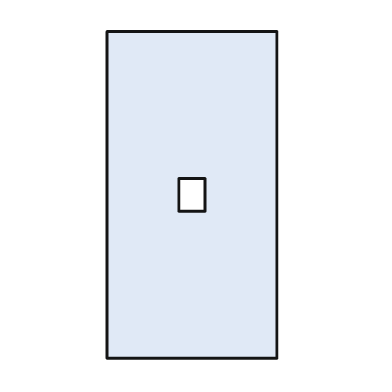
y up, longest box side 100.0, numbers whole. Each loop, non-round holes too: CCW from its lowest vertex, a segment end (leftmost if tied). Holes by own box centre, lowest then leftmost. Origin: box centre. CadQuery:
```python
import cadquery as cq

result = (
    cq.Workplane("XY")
    .moveTo(-26.0, -50.0)
    .lineTo(26.0, -50.0)
    .lineTo(26.0, 50.0)
    .lineTo(-26.0, 50.0)
    .close()
    .moveTo(-4.0, -5.0)
    .lineTo(4.0, -5.0)
    .lineTo(4.0, 5.0)
    .lineTo(-4.0, 5.0)
    .close()
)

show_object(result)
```